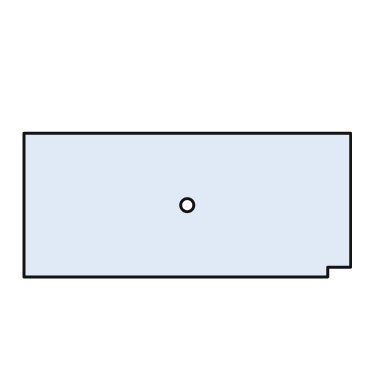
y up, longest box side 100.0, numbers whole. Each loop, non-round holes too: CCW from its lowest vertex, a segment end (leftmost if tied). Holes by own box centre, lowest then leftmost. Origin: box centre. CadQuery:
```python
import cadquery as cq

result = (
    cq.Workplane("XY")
    .moveTo(-50.0, -22.0)
    .lineTo(43.0, -22.0)
    .lineTo(43.0, -19.0)
    .lineTo(50.0, -19.0)
    .lineTo(50.0, 22.0)
    .lineTo(-50.0, 22.0)
    .close()
    .moveTo(0.0, 0.0)
    .circle(2.0)
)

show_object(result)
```